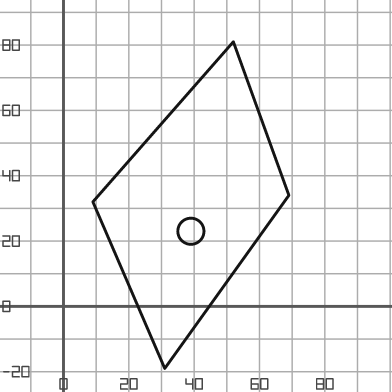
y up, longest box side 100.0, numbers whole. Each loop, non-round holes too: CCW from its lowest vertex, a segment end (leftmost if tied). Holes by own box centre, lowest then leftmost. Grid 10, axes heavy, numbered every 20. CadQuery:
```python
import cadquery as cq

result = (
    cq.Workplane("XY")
    .moveTo(31.0, -19.0)
    .lineTo(69.0, 34.0)
    .lineTo(52.0, 81.0)
    .lineTo(9.0, 32.0)
    .close()
    .moveTo(39.0, 23.0)
    .circle(4.0)
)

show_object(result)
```